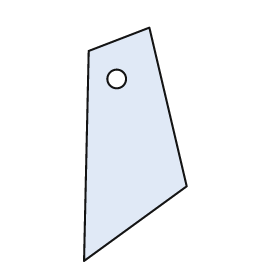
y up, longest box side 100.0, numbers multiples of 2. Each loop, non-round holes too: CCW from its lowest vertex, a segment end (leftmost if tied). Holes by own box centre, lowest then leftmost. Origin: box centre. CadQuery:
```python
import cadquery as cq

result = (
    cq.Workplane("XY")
    .moveTo(-22.0, -50.0)
    .lineTo(22.0, -18.0)
    .lineTo(6.0, 50.0)
    .lineTo(-20.0, 40.0)
    .close()
    .moveTo(-8.0, 28.0)
    .circle(4.0)
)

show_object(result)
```